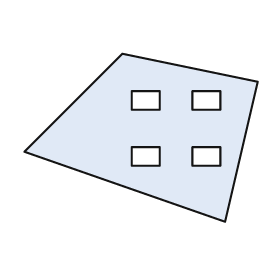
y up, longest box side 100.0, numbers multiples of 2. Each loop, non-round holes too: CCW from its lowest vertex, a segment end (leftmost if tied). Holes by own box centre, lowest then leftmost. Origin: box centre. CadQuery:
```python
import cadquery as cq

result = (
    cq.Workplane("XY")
    .moveTo(36.0, -36.0)
    .lineTo(50.0, 24.0)
    .lineTo(-8.0, 36.0)
    .lineTo(-50.0, -6.0)
    .close()
    .moveTo(-4.0, -12.0)
    .lineTo(8.0, -12.0)
    .lineTo(8.0, -4.0)
    .lineTo(-4.0, -4.0)
    .close()
    .moveTo(22.0, -12.0)
    .lineTo(34.0, -12.0)
    .lineTo(34.0, -4.0)
    .lineTo(22.0, -4.0)
    .close()
    .moveTo(-4.0, 12.0)
    .lineTo(8.0, 12.0)
    .lineTo(8.0, 20.0)
    .lineTo(-4.0, 20.0)
    .close()
    .moveTo(22.0, 12.0)
    .lineTo(34.0, 12.0)
    .lineTo(34.0, 20.0)
    .lineTo(22.0, 20.0)
    .close()
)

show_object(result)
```